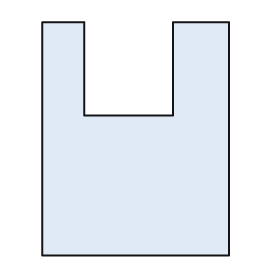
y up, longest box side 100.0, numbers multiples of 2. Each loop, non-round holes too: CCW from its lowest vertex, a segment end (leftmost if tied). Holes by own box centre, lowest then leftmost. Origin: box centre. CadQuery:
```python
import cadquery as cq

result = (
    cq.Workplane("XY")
    .moveTo(-40.0, -50.0)
    .lineTo(40.0, -50.0)
    .lineTo(40.0, 50.0)
    .lineTo(16.0, 50.0)
    .lineTo(16.0, 10.0)
    .lineTo(-22.0, 10.0)
    .lineTo(-22.0, 50.0)
    .lineTo(-40.0, 50.0)
    .close()
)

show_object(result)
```